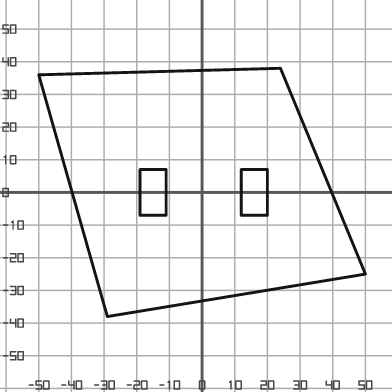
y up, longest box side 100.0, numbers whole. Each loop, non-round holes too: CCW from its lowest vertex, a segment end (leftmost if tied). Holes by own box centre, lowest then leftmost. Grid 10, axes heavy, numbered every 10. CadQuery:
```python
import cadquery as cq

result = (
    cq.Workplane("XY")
    .moveTo(-29.0, -38.0)
    .lineTo(50.0, -25.0)
    .lineTo(24.0, 38.0)
    .lineTo(-50.0, 36.0)
    .close()
    .moveTo(-19.0, -7.0)
    .lineTo(-11.0, -7.0)
    .lineTo(-11.0, 7.0)
    .lineTo(-19.0, 7.0)
    .close()
    .moveTo(12.0, -7.0)
    .lineTo(20.0, -7.0)
    .lineTo(20.0, 7.0)
    .lineTo(12.0, 7.0)
    .close()
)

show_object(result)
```